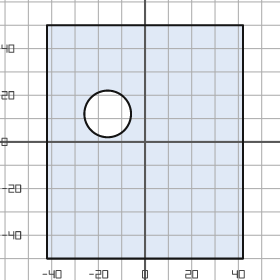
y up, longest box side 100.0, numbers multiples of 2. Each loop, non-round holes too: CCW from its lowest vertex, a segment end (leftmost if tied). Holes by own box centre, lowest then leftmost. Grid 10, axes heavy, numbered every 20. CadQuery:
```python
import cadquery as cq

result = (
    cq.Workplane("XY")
    .moveTo(-42.0, -50.0)
    .lineTo(42.0, -50.0)
    .lineTo(42.0, 50.0)
    .lineTo(-42.0, 50.0)
    .close()
    .moveTo(-16.0, 12.0)
    .circle(10.0)
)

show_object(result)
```